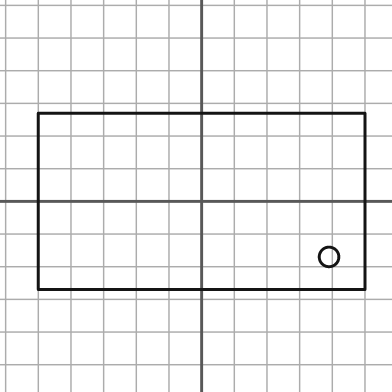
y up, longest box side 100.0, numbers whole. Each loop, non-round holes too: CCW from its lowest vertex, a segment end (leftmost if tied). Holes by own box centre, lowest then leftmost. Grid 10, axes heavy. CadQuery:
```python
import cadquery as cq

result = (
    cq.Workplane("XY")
    .moveTo(-50.0, -27.0)
    .lineTo(50.0, -27.0)
    .lineTo(50.0, 27.0)
    .lineTo(-50.0, 27.0)
    .close()
    .moveTo(39.0, -17.0)
    .circle(3.0)
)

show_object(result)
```